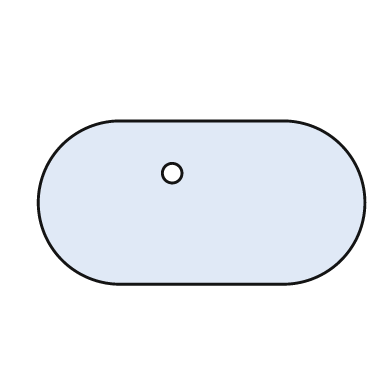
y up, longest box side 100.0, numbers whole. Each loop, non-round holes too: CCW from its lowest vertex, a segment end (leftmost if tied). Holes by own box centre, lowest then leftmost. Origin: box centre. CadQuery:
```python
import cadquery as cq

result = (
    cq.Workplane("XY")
    .moveTo(-25.0, -25.0)
    .lineTo(25.0, -25.0)
    .threePointArc((50.0, 0.0), (25.0, 25.0))
    .lineTo(-25.0, 25.0)
    .threePointArc((-50.0, 0.0), (-25.0, -25.0))
    .close()
    .moveTo(-9.0, 9.0)
    .circle(3.0)
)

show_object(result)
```